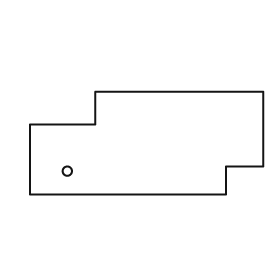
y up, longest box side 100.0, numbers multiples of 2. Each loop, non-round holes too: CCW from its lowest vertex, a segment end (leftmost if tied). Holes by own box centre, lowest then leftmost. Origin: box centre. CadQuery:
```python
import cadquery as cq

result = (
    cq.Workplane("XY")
    .moveTo(-50.0, -22.0)
    .lineTo(34.0, -22.0)
    .lineTo(34.0, -10.0)
    .lineTo(50.0, -10.0)
    .lineTo(50.0, 22.0)
    .lineTo(-22.0, 22.0)
    .lineTo(-22.0, 8.0)
    .lineTo(-50.0, 8.0)
    .close()
    .moveTo(-34.0, -12.0)
    .circle(2.0)
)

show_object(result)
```